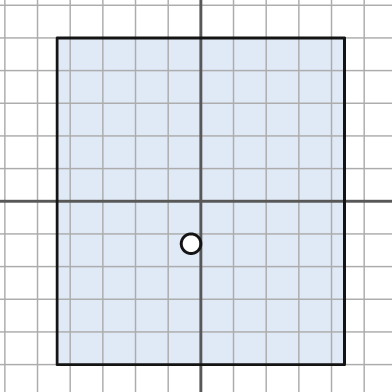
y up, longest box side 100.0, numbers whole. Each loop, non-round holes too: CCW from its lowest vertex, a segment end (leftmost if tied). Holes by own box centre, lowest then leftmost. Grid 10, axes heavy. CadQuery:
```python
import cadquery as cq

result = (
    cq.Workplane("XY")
    .moveTo(-44.0, -50.0)
    .lineTo(44.0, -50.0)
    .lineTo(44.0, 50.0)
    .lineTo(-44.0, 50.0)
    .close()
    .moveTo(-3.0, -13.0)
    .circle(3.0)
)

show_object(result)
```